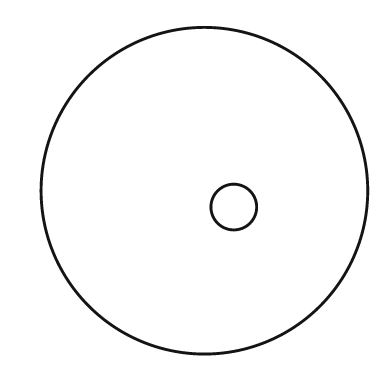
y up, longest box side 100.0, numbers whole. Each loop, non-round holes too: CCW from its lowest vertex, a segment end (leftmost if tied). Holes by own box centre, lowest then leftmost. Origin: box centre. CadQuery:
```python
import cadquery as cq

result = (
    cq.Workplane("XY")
    .moveTo(0.0, 0.0)
    .circle(50.0)
    .moveTo(9.0, -5.0)
    .circle(7.0)
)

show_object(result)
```